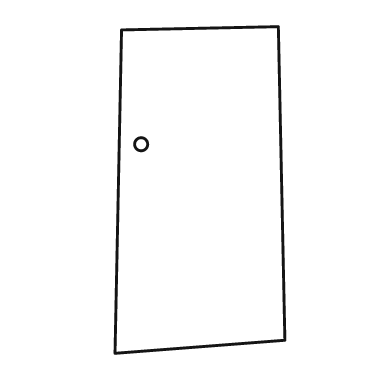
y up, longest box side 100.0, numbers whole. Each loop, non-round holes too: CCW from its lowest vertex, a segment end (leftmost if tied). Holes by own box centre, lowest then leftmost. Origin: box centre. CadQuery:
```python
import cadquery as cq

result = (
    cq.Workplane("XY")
    .moveTo(-26.0, -50.0)
    .lineTo(26.0, -46.0)
    .lineTo(24.0, 50.0)
    .lineTo(-24.0, 49.0)
    .close()
    .moveTo(-18.0, 14.0)
    .circle(2.0)
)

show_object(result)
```